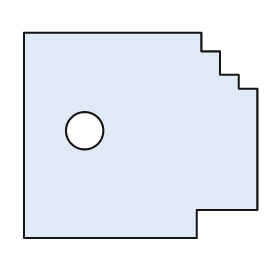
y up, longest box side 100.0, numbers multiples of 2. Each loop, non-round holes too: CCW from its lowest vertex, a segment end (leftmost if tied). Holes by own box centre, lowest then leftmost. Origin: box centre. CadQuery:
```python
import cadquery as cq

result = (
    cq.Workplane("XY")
    .moveTo(-50.0, -44.0)
    .lineTo(24.0, -44.0)
    .lineTo(24.0, -32.0)
    .lineTo(50.0, -32.0)
    .lineTo(50.0, 20.0)
    .lineTo(42.0, 20.0)
    .lineTo(42.0, 26.0)
    .lineTo(34.0, 26.0)
    .lineTo(34.0, 36.0)
    .lineTo(26.0, 36.0)
    .lineTo(26.0, 44.0)
    .lineTo(-50.0, 44.0)
    .close()
    .moveTo(-24.0, 2.0)
    .circle(8.0)
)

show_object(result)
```